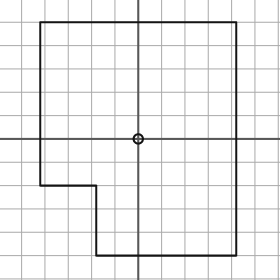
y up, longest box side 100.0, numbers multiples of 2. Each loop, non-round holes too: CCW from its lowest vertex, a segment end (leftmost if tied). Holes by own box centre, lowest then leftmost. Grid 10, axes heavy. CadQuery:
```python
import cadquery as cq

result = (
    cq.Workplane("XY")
    .moveTo(-18.0, -50.0)
    .lineTo(42.0, -50.0)
    .lineTo(42.0, 50.0)
    .lineTo(-42.0, 50.0)
    .lineTo(-42.0, -20.0)
    .lineTo(-18.0, -20.0)
    .close()
    .moveTo(0.0, 0.0)
    .circle(2.0)
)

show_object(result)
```